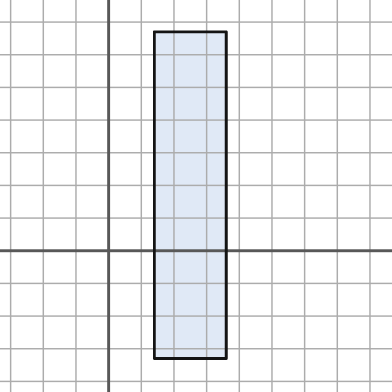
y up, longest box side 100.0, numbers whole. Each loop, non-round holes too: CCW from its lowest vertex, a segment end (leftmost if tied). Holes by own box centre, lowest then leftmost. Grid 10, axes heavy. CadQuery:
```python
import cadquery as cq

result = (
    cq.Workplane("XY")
    .moveTo(14.0, -33.0)
    .lineTo(36.0, -33.0)
    .lineTo(36.0, 67.0)
    .lineTo(14.0, 67.0)
    .close()
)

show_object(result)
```